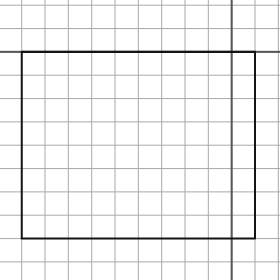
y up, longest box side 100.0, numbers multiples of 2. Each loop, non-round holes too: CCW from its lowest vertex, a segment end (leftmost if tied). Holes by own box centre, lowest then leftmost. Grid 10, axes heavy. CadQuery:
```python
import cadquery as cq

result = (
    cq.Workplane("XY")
    .moveTo(-90.0, -80.0)
    .lineTo(10.0, -80.0)
    .lineTo(10.0, 0.0)
    .lineTo(-90.0, 0.0)
    .close()
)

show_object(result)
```